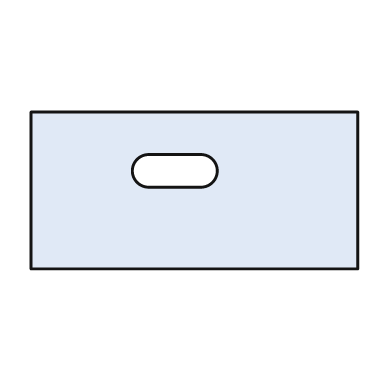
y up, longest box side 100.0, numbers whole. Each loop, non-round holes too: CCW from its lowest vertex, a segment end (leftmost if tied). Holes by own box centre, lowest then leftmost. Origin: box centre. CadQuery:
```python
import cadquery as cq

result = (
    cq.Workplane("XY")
    .moveTo(-50.0, -24.0)
    .lineTo(50.0, -24.0)
    .lineTo(50.0, 24.0)
    .lineTo(-50.0, 24.0)
    .close()
    .moveTo(-14.0, 1.0)
    .lineTo(2.0, 1.0)
    .threePointArc((7.0, 6.0), (2.0, 11.0))
    .lineTo(-14.0, 11.0)
    .threePointArc((-19.0, 6.0), (-14.0, 1.0))
    .close()
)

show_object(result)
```